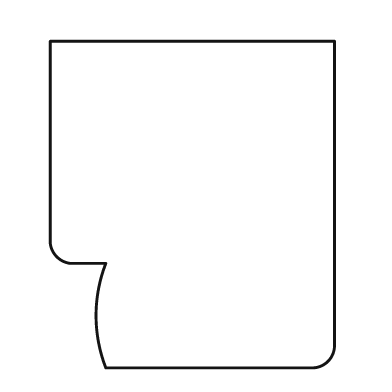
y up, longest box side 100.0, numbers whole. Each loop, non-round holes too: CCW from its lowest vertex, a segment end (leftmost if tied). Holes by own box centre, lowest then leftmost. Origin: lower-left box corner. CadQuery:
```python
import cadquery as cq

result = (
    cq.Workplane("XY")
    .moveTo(17.0, 0.0)
    .lineTo(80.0, 0.0)
    .threePointArc((85.0, 2.0), (87.0, 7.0))
    .lineTo(87.0, 100.0)
    .lineTo(0.0, 100.0)
    .lineTo(0.0, 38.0)
    .threePointArc((2.0, 34.0), (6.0, 32.0))
    .lineTo(17.0, 32.0)
    .threePointArc((14.0, 16.0), (17.0, 0.0))
    .close()
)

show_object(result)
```